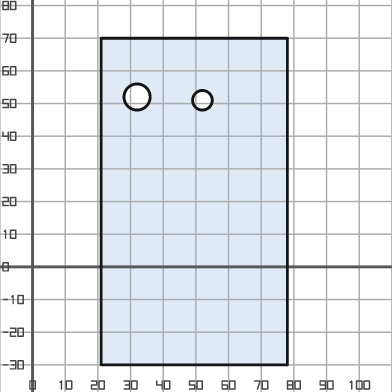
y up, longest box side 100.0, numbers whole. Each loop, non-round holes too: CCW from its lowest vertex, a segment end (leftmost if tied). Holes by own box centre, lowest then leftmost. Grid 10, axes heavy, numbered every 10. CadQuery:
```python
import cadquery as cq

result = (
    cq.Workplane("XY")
    .moveTo(21.0, -30.0)
    .lineTo(78.0, -30.0)
    .lineTo(78.0, 70.0)
    .lineTo(21.0, 70.0)
    .close()
    .moveTo(52.0, 51.0)
    .circle(3.0)
    .moveTo(32.0, 52.0)
    .circle(4.0)
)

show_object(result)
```